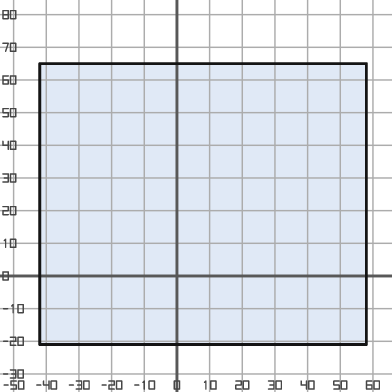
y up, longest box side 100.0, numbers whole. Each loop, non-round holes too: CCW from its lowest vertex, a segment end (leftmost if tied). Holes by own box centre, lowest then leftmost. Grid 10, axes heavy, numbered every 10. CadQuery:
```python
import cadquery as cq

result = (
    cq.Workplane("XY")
    .moveTo(-42.0, -21.0)
    .lineTo(58.0, -21.0)
    .lineTo(58.0, 65.0)
    .lineTo(-42.0, 65.0)
    .close()
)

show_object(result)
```